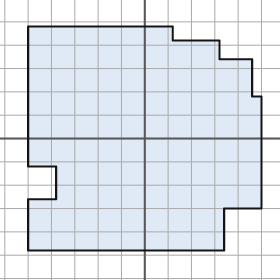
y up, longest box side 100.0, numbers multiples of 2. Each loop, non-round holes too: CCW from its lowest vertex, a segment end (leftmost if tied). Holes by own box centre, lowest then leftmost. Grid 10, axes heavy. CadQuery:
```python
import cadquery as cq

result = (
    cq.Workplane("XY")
    .moveTo(-50.0, -48.0)
    .lineTo(34.0, -48.0)
    .lineTo(34.0, -30.0)
    .lineTo(50.0, -30.0)
    .lineTo(50.0, 18.0)
    .lineTo(46.0, 18.0)
    .lineTo(46.0, 34.0)
    .lineTo(32.0, 34.0)
    .lineTo(32.0, 42.0)
    .lineTo(12.0, 42.0)
    .lineTo(12.0, 48.0)
    .lineTo(-50.0, 48.0)
    .lineTo(-50.0, -12.0)
    .lineTo(-38.0, -12.0)
    .lineTo(-38.0, -26.0)
    .lineTo(-50.0, -26.0)
    .close()
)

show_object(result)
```